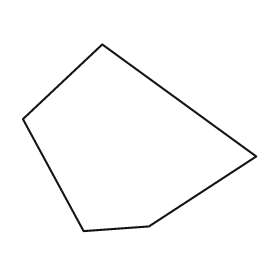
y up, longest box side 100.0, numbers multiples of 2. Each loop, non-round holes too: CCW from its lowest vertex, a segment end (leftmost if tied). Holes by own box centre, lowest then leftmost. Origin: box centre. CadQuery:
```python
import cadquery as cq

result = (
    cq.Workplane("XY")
    .moveTo(-24.0, -40.0)
    .lineTo(4.0, -38.0)
    .lineTo(50.0, -8.0)
    .lineTo(-16.0, 40.0)
    .lineTo(-50.0, 8.0)
    .close()
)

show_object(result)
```